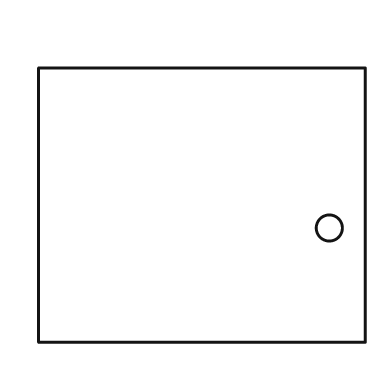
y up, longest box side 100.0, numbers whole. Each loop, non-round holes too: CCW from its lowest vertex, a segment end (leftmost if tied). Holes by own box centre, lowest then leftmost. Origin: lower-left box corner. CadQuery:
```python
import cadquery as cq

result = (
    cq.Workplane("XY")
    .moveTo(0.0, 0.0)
    .lineTo(100.0, 0.0)
    .lineTo(100.0, 84.0)
    .lineTo(0.0, 84.0)
    .close()
    .moveTo(89.0, 35.0)
    .circle(4.0)
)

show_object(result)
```